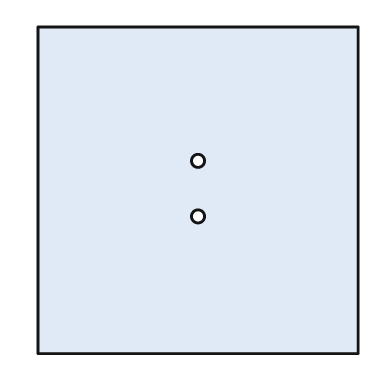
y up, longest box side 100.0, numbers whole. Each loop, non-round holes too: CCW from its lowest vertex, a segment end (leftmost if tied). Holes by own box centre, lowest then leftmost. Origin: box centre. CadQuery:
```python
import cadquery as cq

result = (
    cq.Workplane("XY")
    .moveTo(-49.0, -50.0)
    .lineTo(49.0, -50.0)
    .lineTo(49.0, 50.0)
    .lineTo(-49.0, 50.0)
    .close()
    .moveTo(0.0, -8.0)
    .circle(2.0)
    .moveTo(0.0, 9.0)
    .circle(2.0)
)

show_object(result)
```